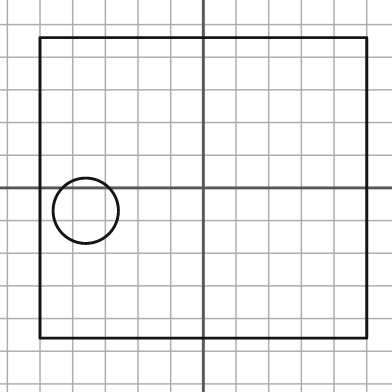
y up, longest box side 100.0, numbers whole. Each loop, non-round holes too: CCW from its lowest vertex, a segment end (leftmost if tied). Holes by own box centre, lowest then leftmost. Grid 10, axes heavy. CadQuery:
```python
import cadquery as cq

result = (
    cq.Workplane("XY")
    .moveTo(-50.0, -46.0)
    .lineTo(50.0, -46.0)
    .lineTo(50.0, 46.0)
    .lineTo(-50.0, 46.0)
    .close()
    .moveTo(-36.0, -7.0)
    .circle(10.0)
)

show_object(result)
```